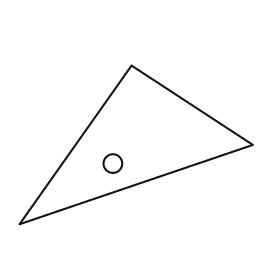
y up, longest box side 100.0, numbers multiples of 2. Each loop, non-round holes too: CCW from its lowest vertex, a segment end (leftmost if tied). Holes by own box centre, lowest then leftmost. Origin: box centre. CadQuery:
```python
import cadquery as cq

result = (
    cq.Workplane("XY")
    .moveTo(-50.0, -34.0)
    .lineTo(50.0, 0.0)
    .lineTo(-2.0, 34.0)
    .close()
    .moveTo(-10.0, -8.0)
    .circle(4.0)
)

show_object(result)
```